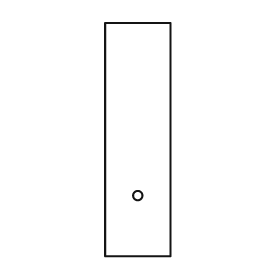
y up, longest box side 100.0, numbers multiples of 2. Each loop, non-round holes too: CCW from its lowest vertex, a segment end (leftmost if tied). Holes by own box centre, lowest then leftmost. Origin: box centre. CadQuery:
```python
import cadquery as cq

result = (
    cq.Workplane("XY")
    .moveTo(-14.0, -50.0)
    .lineTo(14.0, -50.0)
    .lineTo(14.0, 50.0)
    .lineTo(-14.0, 50.0)
    .close()
    .moveTo(0.0, -24.0)
    .circle(2.0)
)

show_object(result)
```